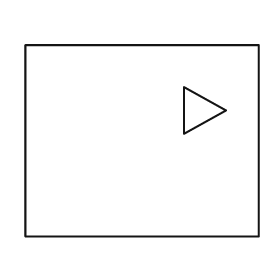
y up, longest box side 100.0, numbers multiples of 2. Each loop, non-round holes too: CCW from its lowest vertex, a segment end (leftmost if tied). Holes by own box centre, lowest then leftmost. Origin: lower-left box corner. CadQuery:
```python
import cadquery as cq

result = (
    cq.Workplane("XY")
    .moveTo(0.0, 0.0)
    .lineTo(100.0, 0.0)
    .lineTo(100.0, 82.0)
    .lineTo(0.0, 82.0)
    .close()
    .moveTo(68.0, 44.0)
    .lineTo(86.0, 54.0)
    .lineTo(68.0, 64.0)
    .close()
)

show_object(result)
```